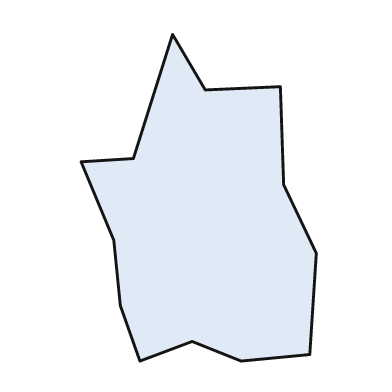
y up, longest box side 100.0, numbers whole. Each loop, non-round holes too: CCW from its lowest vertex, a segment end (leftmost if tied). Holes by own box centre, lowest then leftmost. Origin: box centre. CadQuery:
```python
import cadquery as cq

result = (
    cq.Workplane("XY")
    .moveTo(-18.0, -50.0)
    .lineTo(-2.0, -44.0)
    .lineTo(13.0, -50.0)
    .lineTo(34.0, -48.0)
    .lineTo(36.0, -17.0)
    .lineTo(26.0, 4.0)
    .lineTo(25.0, 34.0)
    .lineTo(2.0, 33.0)
    .lineTo(-8.0, 50.0)
    .lineTo(-20.0, 12.0)
    .lineTo(-36.0, 11.0)
    .lineTo(-26.0, -13.0)
    .lineTo(-24.0, -33.0)
    .close()
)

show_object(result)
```